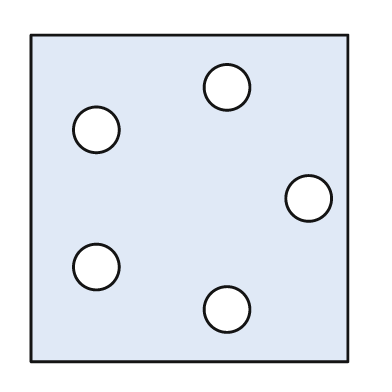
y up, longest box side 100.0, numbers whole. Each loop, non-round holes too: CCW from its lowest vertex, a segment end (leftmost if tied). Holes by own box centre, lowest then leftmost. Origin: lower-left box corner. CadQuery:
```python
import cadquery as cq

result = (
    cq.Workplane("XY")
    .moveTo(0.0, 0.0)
    .lineTo(97.0, 0.0)
    .lineTo(97.0, 100.0)
    .lineTo(0.0, 100.0)
    .close()
    .moveTo(60.0, 16.0)
    .circle(7.0)
    .moveTo(20.0, 29.0)
    .circle(7.0)
    .moveTo(85.0, 50.0)
    .circle(7.0)
    .moveTo(20.0, 71.0)
    .circle(7.0)
    .moveTo(60.0, 84.0)
    .circle(7.0)
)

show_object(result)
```